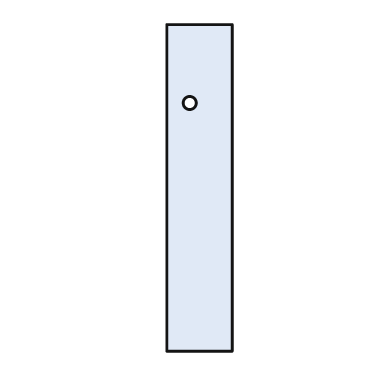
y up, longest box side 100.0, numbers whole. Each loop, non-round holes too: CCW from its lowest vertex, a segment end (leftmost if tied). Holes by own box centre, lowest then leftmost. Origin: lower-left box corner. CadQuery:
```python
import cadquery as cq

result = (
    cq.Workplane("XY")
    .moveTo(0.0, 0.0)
    .lineTo(20.0, 0.0)
    .lineTo(20.0, 100.0)
    .lineTo(0.0, 100.0)
    .close()
    .moveTo(7.0, 76.0)
    .circle(2.0)
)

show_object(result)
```